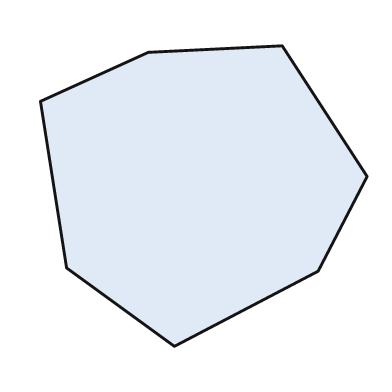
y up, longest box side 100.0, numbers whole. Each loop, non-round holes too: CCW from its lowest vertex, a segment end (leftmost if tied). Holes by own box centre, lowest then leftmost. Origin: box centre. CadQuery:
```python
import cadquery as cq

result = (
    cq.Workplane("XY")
    .moveTo(-9.0, -46.0)
    .lineTo(35.0, -23.0)
    .lineTo(50.0, 6.0)
    .lineTo(24.0, 46.0)
    .lineTo(-17.0, 44.0)
    .lineTo(-50.0, 29.0)
    .lineTo(-42.0, -22.0)
    .close()
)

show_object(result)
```